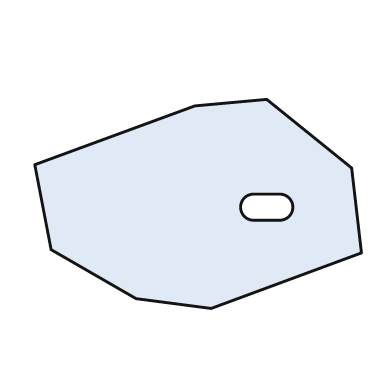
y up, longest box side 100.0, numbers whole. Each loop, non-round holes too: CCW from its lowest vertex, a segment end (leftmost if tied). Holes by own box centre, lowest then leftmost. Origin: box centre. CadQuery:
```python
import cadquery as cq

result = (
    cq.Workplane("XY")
    .moveTo(4.0, -32.0)
    .lineTo(50.0, -15.0)
    .lineTo(47.0, 11.0)
    .lineTo(21.0, 32.0)
    .lineTo(-1.0, 30.0)
    .lineTo(-50.0, 12.0)
    .lineTo(-45.0, -14.0)
    .lineTo(-19.0, -29.0)
    .close()
    .moveTo(17.0, -5.0)
    .lineTo(25.0, -5.0)
    .threePointArc((29.0, -1.0), (25.0, 3.0))
    .lineTo(17.0, 3.0)
    .threePointArc((13.0, -1.0), (17.0, -5.0))
    .close()
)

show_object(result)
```